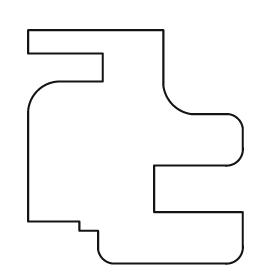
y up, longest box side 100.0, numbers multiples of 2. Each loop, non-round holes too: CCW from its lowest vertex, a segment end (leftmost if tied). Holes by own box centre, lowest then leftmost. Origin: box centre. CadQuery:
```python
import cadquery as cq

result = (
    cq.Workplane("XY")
    .moveTo(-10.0, -50.0)
    .lineTo(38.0, -50.0)
    .threePointArc((44.0, -48.0), (46.0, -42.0))
    .lineTo(46.0, -28.0)
    .lineTo(8.0, -28.0)
    .lineTo(8.0, -8.0)
    .lineTo(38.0, -8.0)
    .threePointArc((44.0, -6.0), (46.0, 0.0))
    .lineTo(46.0, 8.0)
    .threePointArc((44.0, 12.0), (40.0, 14.0))
    .lineTo(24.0, 14.0)
    .threePointArc((16.0, 18.0), (12.0, 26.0))
    .lineTo(12.0, 50.0)
    .lineTo(-46.0, 50.0)
    .lineTo(-46.0, 40.0)
    .lineTo(-14.0, 40.0)
    .lineTo(-14.0, 28.0)
    .lineTo(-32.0, 28.0)
    .threePointArc((-42.0, 24.0), (-46.0, 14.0))
    .lineTo(-46.0, -32.0)
    .lineTo(-24.0, -32.0)
    .lineTo(-24.0, -36.0)
    .lineTo(-16.0, -36.0)
    .lineTo(-16.0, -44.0)
    .threePointArc((-14.0, -48.0), (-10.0, -50.0))
    .close()
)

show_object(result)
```